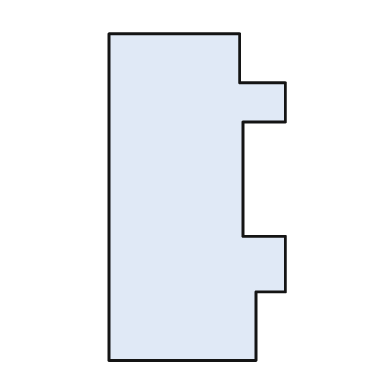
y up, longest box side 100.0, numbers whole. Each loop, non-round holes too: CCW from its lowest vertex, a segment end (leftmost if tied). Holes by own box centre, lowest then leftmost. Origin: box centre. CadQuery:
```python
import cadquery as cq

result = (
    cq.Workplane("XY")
    .moveTo(-27.0, -50.0)
    .lineTo(18.0, -50.0)
    .lineTo(18.0, -29.0)
    .lineTo(27.0, -29.0)
    .lineTo(27.0, -12.0)
    .lineTo(14.0, -12.0)
    .lineTo(14.0, 23.0)
    .lineTo(27.0, 23.0)
    .lineTo(27.0, 35.0)
    .lineTo(13.0, 35.0)
    .lineTo(13.0, 50.0)
    .lineTo(-27.0, 50.0)
    .close()
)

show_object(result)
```